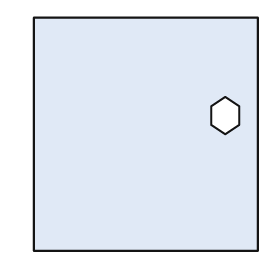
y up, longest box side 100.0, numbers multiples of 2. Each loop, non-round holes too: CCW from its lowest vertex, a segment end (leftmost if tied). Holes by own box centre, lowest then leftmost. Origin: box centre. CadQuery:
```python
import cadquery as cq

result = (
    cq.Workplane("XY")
    .moveTo(-48.0, -50.0)
    .lineTo(48.0, -50.0)
    .lineTo(48.0, 50.0)
    .lineTo(-48.0, 50.0)
    .close()
    .moveTo(34.0, 0.0)
    .lineTo(40.0, 4.0)
    .lineTo(40.0, 12.0)
    .lineTo(34.0, 16.0)
    .lineTo(28.0, 12.0)
    .lineTo(28.0, 4.0)
    .close()
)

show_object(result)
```